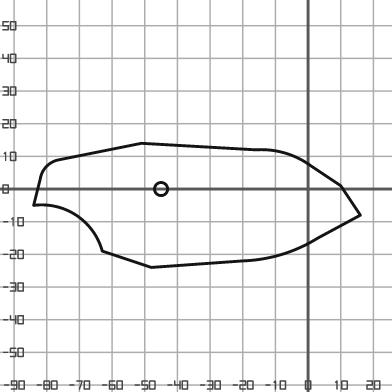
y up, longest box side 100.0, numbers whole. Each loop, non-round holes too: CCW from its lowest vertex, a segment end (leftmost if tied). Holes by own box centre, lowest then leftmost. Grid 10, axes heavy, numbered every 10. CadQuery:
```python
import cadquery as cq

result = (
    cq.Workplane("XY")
    .moveTo(-48.0, -24.0)
    .lineTo(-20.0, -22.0)
    .threePointArc((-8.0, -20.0), (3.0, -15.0))
    .lineTo(16.0, -8.0)
    .lineTo(10.0, 1.0)
    .lineTo(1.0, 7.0)
    .threePointArc((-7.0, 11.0), (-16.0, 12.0))
    .lineTo(-51.0, 14.0)
    .lineTo(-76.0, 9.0)
    .threePointArc((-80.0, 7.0), (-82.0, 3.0))
    .lineTo(-84.0, -5.0)
    .threePointArc((-71.0, -8.0), (-63.0, -19.0))
    .close()
    .moveTo(-45.0, 0.0)
    .circle(2.0)
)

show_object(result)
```